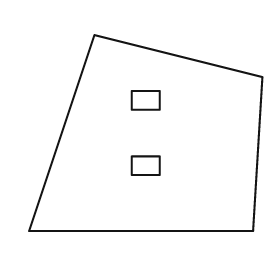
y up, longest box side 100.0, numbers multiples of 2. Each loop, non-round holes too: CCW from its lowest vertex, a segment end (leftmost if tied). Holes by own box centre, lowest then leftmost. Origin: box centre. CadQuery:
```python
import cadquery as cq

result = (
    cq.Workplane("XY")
    .moveTo(-50.0, -42.0)
    .lineTo(46.0, -42.0)
    .lineTo(50.0, 24.0)
    .lineTo(-22.0, 42.0)
    .close()
    .moveTo(-6.0, -18.0)
    .lineTo(6.0, -18.0)
    .lineTo(6.0, -10.0)
    .lineTo(-6.0, -10.0)
    .close()
    .moveTo(-6.0, 10.0)
    .lineTo(6.0, 10.0)
    .lineTo(6.0, 18.0)
    .lineTo(-6.0, 18.0)
    .close()
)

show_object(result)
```